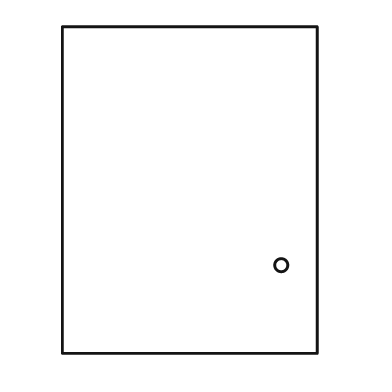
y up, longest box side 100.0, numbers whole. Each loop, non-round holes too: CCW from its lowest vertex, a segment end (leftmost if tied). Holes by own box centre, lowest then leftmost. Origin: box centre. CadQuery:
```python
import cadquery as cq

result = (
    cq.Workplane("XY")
    .moveTo(-39.0, -50.0)
    .lineTo(39.0, -50.0)
    .lineTo(39.0, 50.0)
    .lineTo(-39.0, 50.0)
    .close()
    .moveTo(28.0, -23.0)
    .circle(2.0)
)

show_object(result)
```